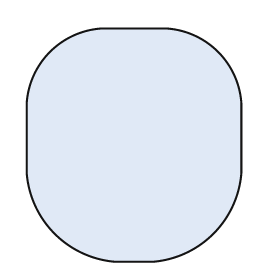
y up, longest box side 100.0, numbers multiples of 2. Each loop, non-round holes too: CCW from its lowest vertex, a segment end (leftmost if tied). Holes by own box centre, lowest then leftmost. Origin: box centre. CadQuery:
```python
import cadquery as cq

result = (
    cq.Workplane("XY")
    .moveTo(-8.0, -50.0)
    .lineTo(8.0, -50.0)
    .threePointArc((34.0, -38.0), (46.0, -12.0))
    .lineTo(46.0, 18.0)
    .threePointArc((36.0, 40.0), (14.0, 50.0))
    .lineTo(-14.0, 50.0)
    .threePointArc((-36.0, 40.0), (-46.0, 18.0))
    .lineTo(-46.0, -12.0)
    .threePointArc((-34.0, -38.0), (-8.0, -50.0))
    .close()
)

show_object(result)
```